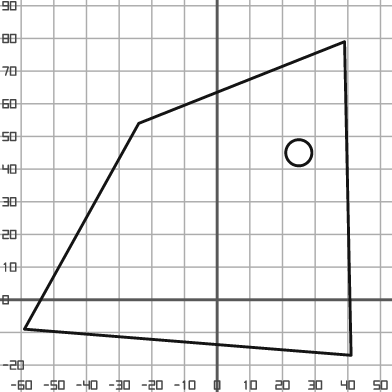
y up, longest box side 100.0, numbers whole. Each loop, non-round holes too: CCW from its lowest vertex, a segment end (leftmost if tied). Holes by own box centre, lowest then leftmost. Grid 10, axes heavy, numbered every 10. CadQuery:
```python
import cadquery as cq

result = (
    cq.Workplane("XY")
    .moveTo(41.0, -17.0)
    .lineTo(39.0, 79.0)
    .lineTo(-24.0, 54.0)
    .lineTo(-59.0, -9.0)
    .close()
    .moveTo(25.0, 45.0)
    .circle(4.0)
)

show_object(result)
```